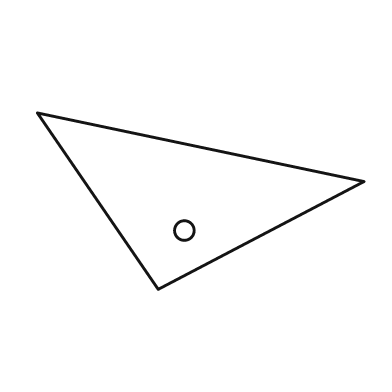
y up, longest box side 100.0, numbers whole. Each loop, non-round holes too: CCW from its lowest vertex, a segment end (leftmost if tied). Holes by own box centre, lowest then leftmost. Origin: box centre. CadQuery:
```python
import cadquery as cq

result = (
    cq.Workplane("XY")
    .moveTo(-13.0, -27.0)
    .lineTo(50.0, 6.0)
    .lineTo(-50.0, 27.0)
    .close()
    .moveTo(-5.0, -9.0)
    .circle(3.0)
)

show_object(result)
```